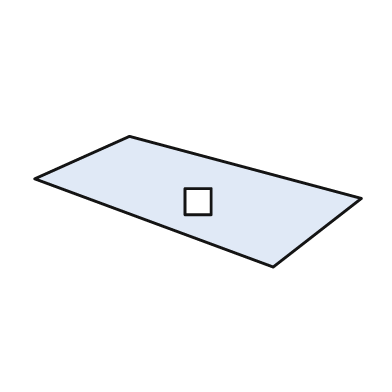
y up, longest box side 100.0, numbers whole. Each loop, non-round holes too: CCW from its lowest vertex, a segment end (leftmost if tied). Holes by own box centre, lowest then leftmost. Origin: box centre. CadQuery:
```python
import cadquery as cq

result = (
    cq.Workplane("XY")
    .moveTo(23.0, -20.0)
    .lineTo(50.0, 1.0)
    .lineTo(-21.0, 20.0)
    .lineTo(-50.0, 7.0)
    .close()
    .moveTo(-4.0, -4.0)
    .lineTo(4.0, -4.0)
    .lineTo(4.0, 4.0)
    .lineTo(-4.0, 4.0)
    .close()
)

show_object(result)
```